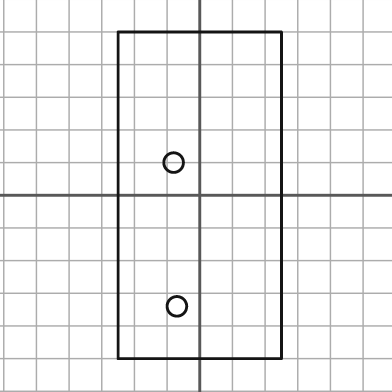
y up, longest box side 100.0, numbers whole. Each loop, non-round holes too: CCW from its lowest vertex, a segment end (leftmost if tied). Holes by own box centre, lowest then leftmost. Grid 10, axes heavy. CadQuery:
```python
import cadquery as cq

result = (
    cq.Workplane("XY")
    .moveTo(-25.0, -50.0)
    .lineTo(25.0, -50.0)
    .lineTo(25.0, 50.0)
    .lineTo(-25.0, 50.0)
    .close()
    .moveTo(-7.0, -34.0)
    .circle(3.0)
    .moveTo(-8.0, 10.0)
    .circle(3.0)
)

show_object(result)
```